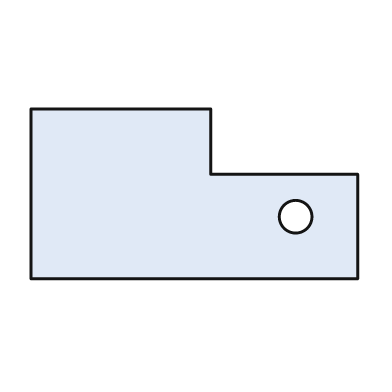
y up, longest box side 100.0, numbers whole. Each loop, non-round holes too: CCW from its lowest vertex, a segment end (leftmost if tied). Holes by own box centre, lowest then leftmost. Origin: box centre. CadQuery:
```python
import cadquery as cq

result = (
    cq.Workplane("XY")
    .moveTo(-50.0, -26.0)
    .lineTo(50.0, -26.0)
    .lineTo(50.0, 6.0)
    .lineTo(5.0, 6.0)
    .lineTo(5.0, 26.0)
    .lineTo(-50.0, 26.0)
    .close()
    .moveTo(31.0, -7.0)
    .circle(5.0)
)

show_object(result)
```